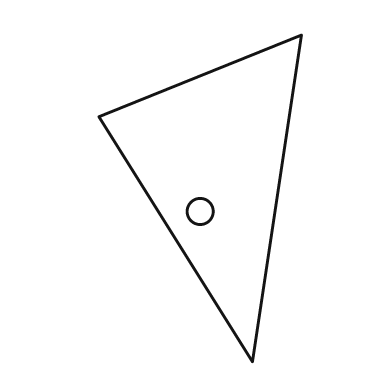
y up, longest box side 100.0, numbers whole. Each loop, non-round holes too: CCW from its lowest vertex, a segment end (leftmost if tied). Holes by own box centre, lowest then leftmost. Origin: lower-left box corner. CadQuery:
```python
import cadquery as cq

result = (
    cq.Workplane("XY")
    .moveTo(47.0, 0.0)
    .lineTo(62.0, 100.0)
    .lineTo(0.0, 75.0)
    .close()
    .moveTo(31.0, 46.0)
    .circle(4.0)
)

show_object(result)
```